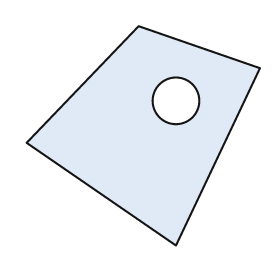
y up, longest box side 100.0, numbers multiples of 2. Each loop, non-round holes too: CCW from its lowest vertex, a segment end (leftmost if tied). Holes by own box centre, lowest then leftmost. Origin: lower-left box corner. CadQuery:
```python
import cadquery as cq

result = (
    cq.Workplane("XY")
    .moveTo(64.0, 0.0)
    .lineTo(100.0, 76.0)
    .lineTo(48.0, 94.0)
    .lineTo(0.0, 44.0)
    .close()
    .moveTo(64.0, 62.0)
    .circle(10.0)
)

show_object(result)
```